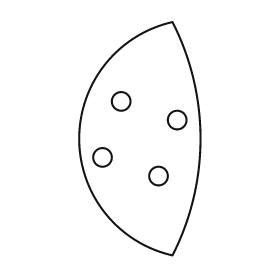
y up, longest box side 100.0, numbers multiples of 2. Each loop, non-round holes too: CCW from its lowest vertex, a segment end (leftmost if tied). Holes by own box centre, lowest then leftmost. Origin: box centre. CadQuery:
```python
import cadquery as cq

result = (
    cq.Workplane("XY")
    .moveTo(14.0, -50.0)
    .threePointArc((26.0, 0.0), (14.0, 50.0))
    .threePointArc((-26.0, 0.0), (14.0, -50.0))
    .close()
    .moveTo(8.0, -16.0)
    .circle(4.0)
    .moveTo(-16.0, -8.0)
    .circle(4.0)
    .moveTo(16.0, 8.0)
    .circle(4.0)
    .moveTo(-8.0, 16.0)
    .circle(4.0)
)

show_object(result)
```